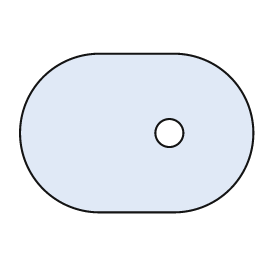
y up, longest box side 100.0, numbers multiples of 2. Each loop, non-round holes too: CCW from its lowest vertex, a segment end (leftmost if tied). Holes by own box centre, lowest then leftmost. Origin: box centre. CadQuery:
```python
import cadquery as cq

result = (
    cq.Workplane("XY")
    .moveTo(-16.0, -34.0)
    .lineTo(16.0, -34.0)
    .threePointArc((50.0, 0.0), (16.0, 34.0))
    .lineTo(-16.0, 34.0)
    .threePointArc((-50.0, 0.0), (-16.0, -34.0))
    .close()
    .moveTo(14.0, 0.0)
    .circle(6.0)
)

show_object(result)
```